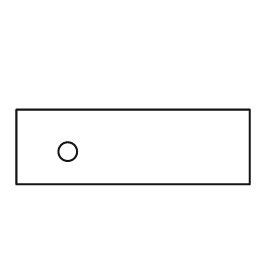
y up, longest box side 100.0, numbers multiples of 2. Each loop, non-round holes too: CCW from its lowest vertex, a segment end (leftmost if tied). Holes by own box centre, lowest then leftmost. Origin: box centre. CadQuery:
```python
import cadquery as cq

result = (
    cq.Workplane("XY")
    .moveTo(-50.0, -16.0)
    .lineTo(50.0, -16.0)
    .lineTo(50.0, 16.0)
    .lineTo(-50.0, 16.0)
    .close()
    .moveTo(-28.0, -2.0)
    .circle(4.0)
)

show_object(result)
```